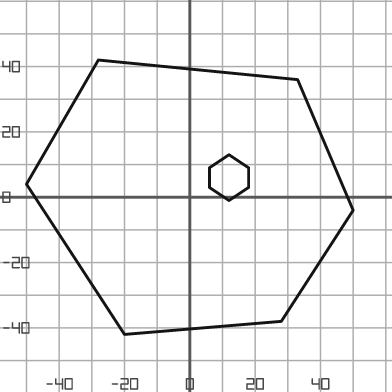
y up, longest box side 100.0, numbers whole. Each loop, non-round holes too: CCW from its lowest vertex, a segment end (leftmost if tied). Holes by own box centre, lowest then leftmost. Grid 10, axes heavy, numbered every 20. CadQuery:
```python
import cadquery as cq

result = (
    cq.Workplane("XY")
    .moveTo(-20.0, -42.0)
    .lineTo(28.0, -38.0)
    .lineTo(50.0, -4.0)
    .lineTo(33.0, 36.0)
    .lineTo(-28.0, 42.0)
    .lineTo(-50.0, 4.0)
    .close()
    .moveTo(12.0, -1.0)
    .lineTo(18.0, 3.0)
    .lineTo(18.0, 9.0)
    .lineTo(12.0, 13.0)
    .lineTo(6.0, 9.0)
    .lineTo(6.0, 3.0)
    .close()
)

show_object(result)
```